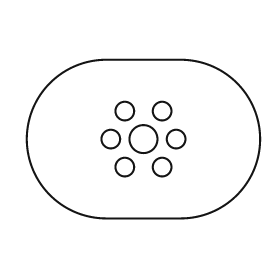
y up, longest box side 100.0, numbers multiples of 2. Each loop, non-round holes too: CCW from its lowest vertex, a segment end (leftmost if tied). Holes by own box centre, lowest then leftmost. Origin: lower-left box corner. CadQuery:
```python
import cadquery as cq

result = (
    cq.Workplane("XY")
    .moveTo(34.0, 0.0)
    .lineTo(66.0, 0.0)
    .threePointArc((100.0, 34.0), (66.0, 68.0))
    .lineTo(34.0, 68.0)
    .threePointArc((0.0, 34.0), (34.0, 0.0))
    .close()
    .moveTo(42.0, 22.0)
    .circle(4.0)
    .moveTo(58.0, 22.0)
    .circle(4.0)
    .moveTo(36.0, 34.0)
    .circle(4.0)
    .moveTo(50.0, 34.0)
    .circle(6.0)
    .moveTo(64.0, 34.0)
    .circle(4.0)
    .moveTo(42.0, 46.0)
    .circle(4.0)
    .moveTo(58.0, 46.0)
    .circle(4.0)
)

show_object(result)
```